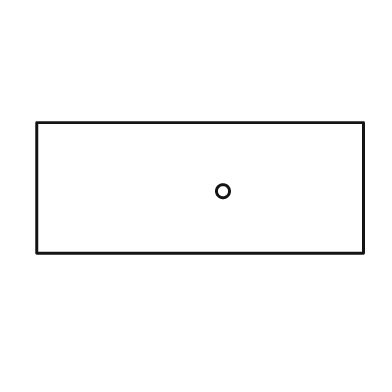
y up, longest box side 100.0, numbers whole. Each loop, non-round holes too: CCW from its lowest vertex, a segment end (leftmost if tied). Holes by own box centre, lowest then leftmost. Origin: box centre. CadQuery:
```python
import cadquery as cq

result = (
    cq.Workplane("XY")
    .moveTo(-50.0, -20.0)
    .lineTo(50.0, -20.0)
    .lineTo(50.0, 20.0)
    .lineTo(-50.0, 20.0)
    .close()
    .moveTo(7.0, -1.0)
    .circle(2.0)
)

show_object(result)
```